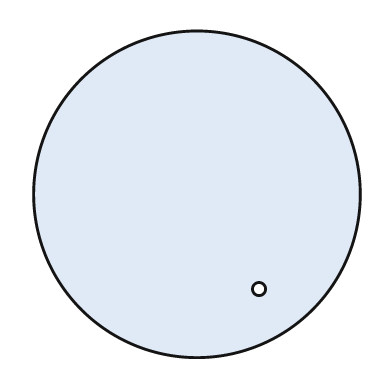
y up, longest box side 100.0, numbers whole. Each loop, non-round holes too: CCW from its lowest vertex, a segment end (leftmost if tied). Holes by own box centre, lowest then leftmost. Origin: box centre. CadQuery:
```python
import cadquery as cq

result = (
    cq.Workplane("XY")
    .moveTo(0.0, 0.0)
    .circle(50.0)
    .moveTo(19.0, -29.0)
    .circle(2.0)
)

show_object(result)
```